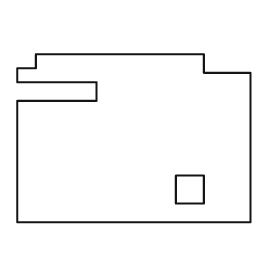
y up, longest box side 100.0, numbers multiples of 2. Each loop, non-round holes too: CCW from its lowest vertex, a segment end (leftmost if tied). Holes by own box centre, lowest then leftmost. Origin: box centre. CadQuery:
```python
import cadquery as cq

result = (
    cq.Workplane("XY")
    .moveTo(-50.0, -36.0)
    .lineTo(50.0, -36.0)
    .lineTo(50.0, 28.0)
    .lineTo(30.0, 28.0)
    .lineTo(30.0, 36.0)
    .lineTo(-42.0, 36.0)
    .lineTo(-42.0, 30.0)
    .lineTo(-50.0, 30.0)
    .lineTo(-50.0, 24.0)
    .lineTo(-16.0, 24.0)
    .lineTo(-16.0, 16.0)
    .lineTo(-50.0, 16.0)
    .close()
    .moveTo(18.0, -28.0)
    .lineTo(30.0, -28.0)
    .lineTo(30.0, -16.0)
    .lineTo(18.0, -16.0)
    .close()
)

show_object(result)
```